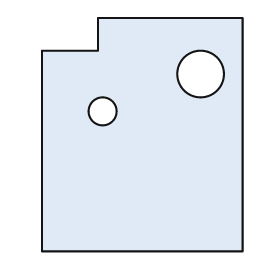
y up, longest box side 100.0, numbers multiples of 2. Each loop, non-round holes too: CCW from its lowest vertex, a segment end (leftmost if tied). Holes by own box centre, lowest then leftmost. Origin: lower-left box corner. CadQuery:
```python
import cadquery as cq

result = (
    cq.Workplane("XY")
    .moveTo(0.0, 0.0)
    .lineTo(86.0, 0.0)
    .lineTo(86.0, 100.0)
    .lineTo(24.0, 100.0)
    .lineTo(24.0, 86.0)
    .lineTo(0.0, 86.0)
    .close()
    .moveTo(26.0, 60.0)
    .circle(6.0)
    .moveTo(68.0, 76.0)
    .circle(10.0)
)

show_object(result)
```